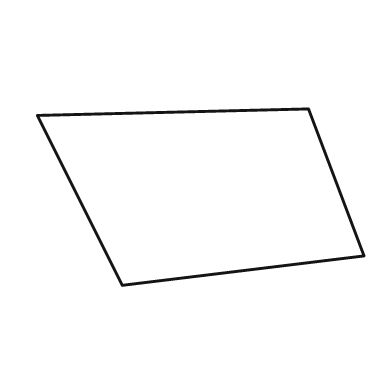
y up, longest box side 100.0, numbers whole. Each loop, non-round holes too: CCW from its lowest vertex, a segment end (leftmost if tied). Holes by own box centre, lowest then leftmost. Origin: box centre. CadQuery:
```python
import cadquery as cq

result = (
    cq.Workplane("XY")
    .moveTo(-24.0, -27.0)
    .lineTo(50.0, -18.0)
    .lineTo(33.0, 27.0)
    .lineTo(-50.0, 25.0)
    .close()
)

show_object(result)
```